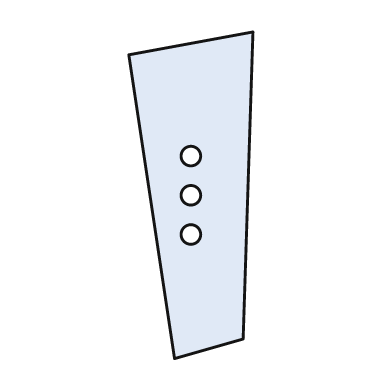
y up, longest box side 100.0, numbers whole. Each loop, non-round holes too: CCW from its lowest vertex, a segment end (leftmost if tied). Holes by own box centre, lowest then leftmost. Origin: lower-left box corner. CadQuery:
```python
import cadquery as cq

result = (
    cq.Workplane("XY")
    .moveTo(14.0, 0.0)
    .lineTo(35.0, 6.0)
    .lineTo(38.0, 100.0)
    .lineTo(0.0, 93.0)
    .close()
    .moveTo(19.0, 38.0)
    .circle(3.0)
    .moveTo(19.0, 50.0)
    .circle(3.0)
    .moveTo(19.0, 62.0)
    .circle(3.0)
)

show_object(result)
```